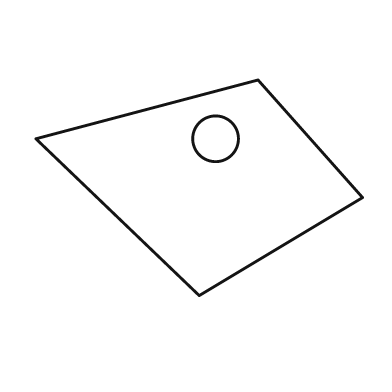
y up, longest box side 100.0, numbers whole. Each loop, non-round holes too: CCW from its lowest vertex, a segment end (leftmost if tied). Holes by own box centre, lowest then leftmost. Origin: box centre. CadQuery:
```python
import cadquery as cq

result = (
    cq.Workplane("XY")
    .moveTo(0.0, -33.0)
    .lineTo(50.0, -3.0)
    .lineTo(18.0, 33.0)
    .lineTo(-50.0, 15.0)
    .close()
    .moveTo(5.0, 15.0)
    .circle(7.0)
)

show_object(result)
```